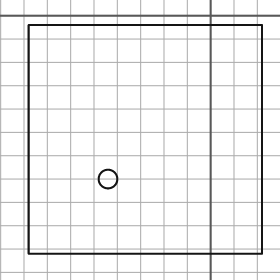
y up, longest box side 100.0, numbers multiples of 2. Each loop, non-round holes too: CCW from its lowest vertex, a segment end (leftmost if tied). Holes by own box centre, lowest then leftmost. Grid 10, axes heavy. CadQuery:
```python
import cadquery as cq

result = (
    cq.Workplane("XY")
    .moveTo(-78.0, -102.0)
    .lineTo(22.0, -102.0)
    .lineTo(22.0, -4.0)
    .lineTo(-78.0, -4.0)
    .close()
    .moveTo(-44.0, -70.0)
    .circle(4.0)
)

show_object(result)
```